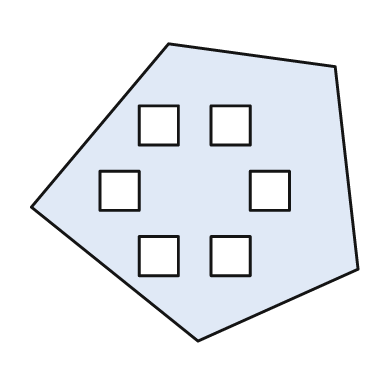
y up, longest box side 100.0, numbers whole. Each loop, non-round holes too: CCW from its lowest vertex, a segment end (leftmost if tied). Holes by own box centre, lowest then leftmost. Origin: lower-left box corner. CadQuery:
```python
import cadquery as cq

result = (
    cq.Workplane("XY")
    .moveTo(51.0, 0.0)
    .lineTo(100.0, 22.0)
    .lineTo(93.0, 84.0)
    .lineTo(42.0, 91.0)
    .lineTo(0.0, 41.0)
    .close()
    .moveTo(33.0, 20.0)
    .lineTo(45.0, 20.0)
    .lineTo(45.0, 32.0)
    .lineTo(33.0, 32.0)
    .close()
    .moveTo(55.0, 20.0)
    .lineTo(67.0, 20.0)
    .lineTo(67.0, 32.0)
    .lineTo(55.0, 32.0)
    .close()
    .moveTo(21.0, 40.0)
    .lineTo(33.0, 40.0)
    .lineTo(33.0, 52.0)
    .lineTo(21.0, 52.0)
    .close()
    .moveTo(67.0, 40.0)
    .lineTo(79.0, 40.0)
    .lineTo(79.0, 52.0)
    .lineTo(67.0, 52.0)
    .close()
    .moveTo(33.0, 60.0)
    .lineTo(45.0, 60.0)
    .lineTo(45.0, 72.0)
    .lineTo(33.0, 72.0)
    .close()
    .moveTo(55.0, 60.0)
    .lineTo(67.0, 60.0)
    .lineTo(67.0, 72.0)
    .lineTo(55.0, 72.0)
    .close()
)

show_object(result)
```